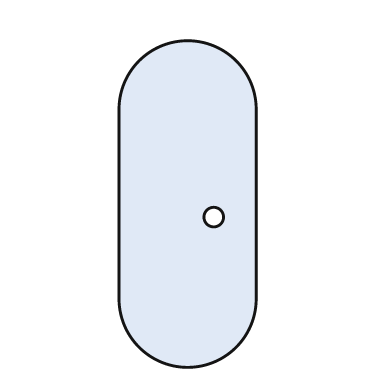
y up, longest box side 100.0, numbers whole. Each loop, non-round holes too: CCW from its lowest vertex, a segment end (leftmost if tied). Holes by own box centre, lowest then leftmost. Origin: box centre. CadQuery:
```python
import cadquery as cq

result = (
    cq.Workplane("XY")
    .moveTo(-21.0, -29.0)
    .threePointArc((0.0, -50.0), (21.0, -29.0))
    .lineTo(21.0, 29.0)
    .threePointArc((0.0, 50.0), (-21.0, 29.0))
    .close()
    .moveTo(8.0, -4.0)
    .circle(3.0)
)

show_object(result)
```